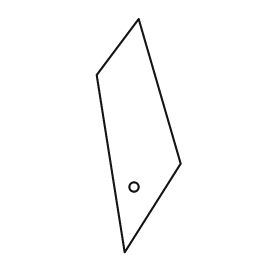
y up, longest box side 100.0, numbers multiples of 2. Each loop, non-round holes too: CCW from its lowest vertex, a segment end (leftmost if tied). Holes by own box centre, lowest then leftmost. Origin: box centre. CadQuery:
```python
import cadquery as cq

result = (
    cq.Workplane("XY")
    .moveTo(-6.0, -50.0)
    .lineTo(18.0, -12.0)
    .lineTo(0.0, 50.0)
    .lineTo(-18.0, 26.0)
    .close()
    .moveTo(-2.0, -22.0)
    .circle(2.0)
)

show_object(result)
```